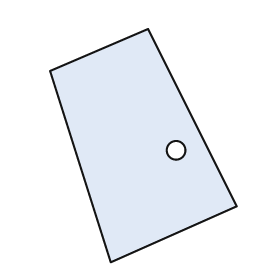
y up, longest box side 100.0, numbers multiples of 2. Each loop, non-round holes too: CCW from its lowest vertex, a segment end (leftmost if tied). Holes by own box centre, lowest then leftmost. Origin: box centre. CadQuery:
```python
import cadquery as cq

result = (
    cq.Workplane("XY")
    .moveTo(-14.0, -50.0)
    .lineTo(40.0, -26.0)
    .lineTo(2.0, 50.0)
    .lineTo(-40.0, 32.0)
    .close()
    .moveTo(14.0, -2.0)
    .circle(4.0)
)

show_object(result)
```